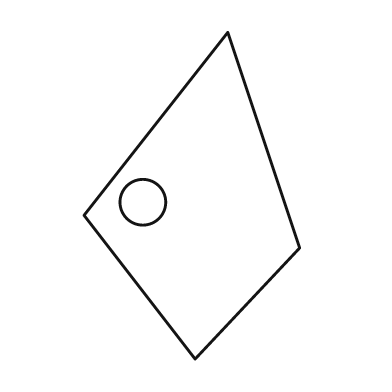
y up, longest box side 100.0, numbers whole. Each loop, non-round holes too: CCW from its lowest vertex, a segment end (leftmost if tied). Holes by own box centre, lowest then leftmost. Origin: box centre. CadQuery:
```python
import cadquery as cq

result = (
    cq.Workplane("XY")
    .moveTo(1.0, -50.0)
    .lineTo(33.0, -16.0)
    .lineTo(11.0, 50.0)
    .lineTo(-33.0, -6.0)
    .close()
    .moveTo(-15.0, -2.0)
    .circle(7.0)
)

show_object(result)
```